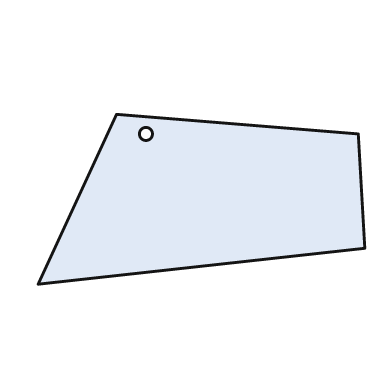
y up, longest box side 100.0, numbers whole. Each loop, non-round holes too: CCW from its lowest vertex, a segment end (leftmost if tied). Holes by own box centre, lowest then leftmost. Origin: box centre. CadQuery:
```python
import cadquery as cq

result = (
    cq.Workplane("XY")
    .moveTo(-50.0, -26.0)
    .lineTo(50.0, -15.0)
    .lineTo(48.0, 20.0)
    .lineTo(-26.0, 26.0)
    .close()
    .moveTo(-17.0, 20.0)
    .circle(2.0)
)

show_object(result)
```